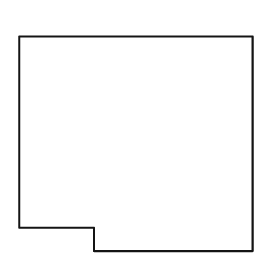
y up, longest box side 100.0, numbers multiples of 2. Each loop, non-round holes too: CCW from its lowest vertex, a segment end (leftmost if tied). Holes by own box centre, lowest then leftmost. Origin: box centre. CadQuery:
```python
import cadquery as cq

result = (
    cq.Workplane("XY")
    .moveTo(-18.0, -46.0)
    .lineTo(50.0, -46.0)
    .lineTo(50.0, 46.0)
    .lineTo(-50.0, 46.0)
    .lineTo(-50.0, -36.0)
    .lineTo(-18.0, -36.0)
    .close()
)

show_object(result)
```